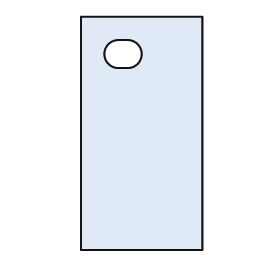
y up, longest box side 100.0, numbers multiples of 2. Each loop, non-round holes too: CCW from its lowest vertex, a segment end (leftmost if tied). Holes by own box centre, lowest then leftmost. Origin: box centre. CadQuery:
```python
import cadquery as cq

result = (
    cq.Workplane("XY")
    .moveTo(-26.0, -50.0)
    .lineTo(26.0, -50.0)
    .lineTo(26.0, 50.0)
    .lineTo(-26.0, 50.0)
    .close()
    .moveTo(-10.0, 28.0)
    .lineTo(-6.0, 28.0)
    .threePointArc((0.0, 34.0), (-6.0, 40.0))
    .lineTo(-10.0, 40.0)
    .threePointArc((-16.0, 34.0), (-10.0, 28.0))
    .close()
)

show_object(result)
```